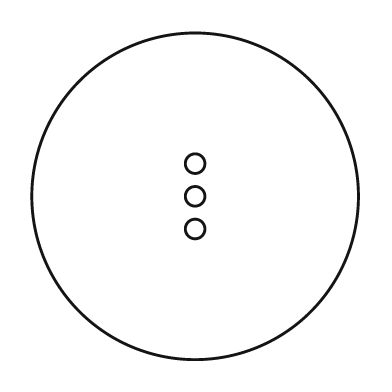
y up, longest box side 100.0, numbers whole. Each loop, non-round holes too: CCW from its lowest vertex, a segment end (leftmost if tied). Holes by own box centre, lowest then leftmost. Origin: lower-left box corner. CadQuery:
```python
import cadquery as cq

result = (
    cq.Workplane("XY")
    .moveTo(50.0, 50.0)
    .circle(50.0)
    .moveTo(50.0, 40.0)
    .circle(3.0)
    .moveTo(50.0, 50.0)
    .circle(3.0)
    .moveTo(50.0, 60.0)
    .circle(3.0)
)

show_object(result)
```